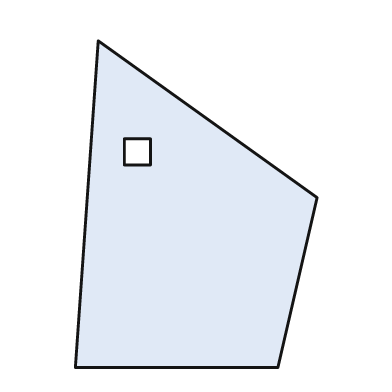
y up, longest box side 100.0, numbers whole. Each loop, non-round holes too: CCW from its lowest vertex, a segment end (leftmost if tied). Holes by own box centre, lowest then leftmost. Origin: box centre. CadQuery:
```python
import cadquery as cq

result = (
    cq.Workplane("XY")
    .moveTo(-37.0, -50.0)
    .lineTo(25.0, -50.0)
    .lineTo(37.0, 2.0)
    .lineTo(-30.0, 50.0)
    .close()
    .moveTo(-22.0, 12.0)
    .lineTo(-14.0, 12.0)
    .lineTo(-14.0, 20.0)
    .lineTo(-22.0, 20.0)
    .close()
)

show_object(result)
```